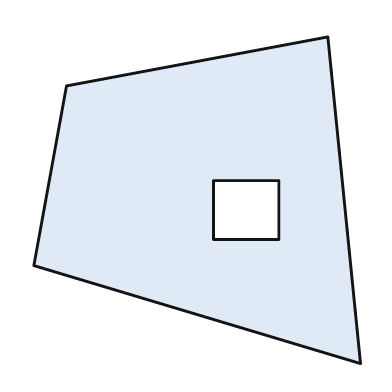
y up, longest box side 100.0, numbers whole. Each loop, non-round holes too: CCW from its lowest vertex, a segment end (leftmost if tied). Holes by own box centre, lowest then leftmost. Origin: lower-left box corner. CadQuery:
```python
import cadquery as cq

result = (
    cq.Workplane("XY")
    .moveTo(100.0, 0.0)
    .lineTo(90.0, 100.0)
    .lineTo(10.0, 85.0)
    .lineTo(0.0, 30.0)
    .close()
    .moveTo(55.0, 38.0)
    .lineTo(75.0, 38.0)
    .lineTo(75.0, 56.0)
    .lineTo(55.0, 56.0)
    .close()
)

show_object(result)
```